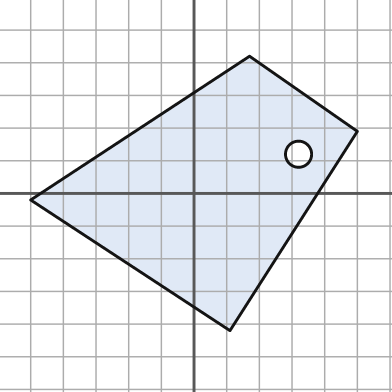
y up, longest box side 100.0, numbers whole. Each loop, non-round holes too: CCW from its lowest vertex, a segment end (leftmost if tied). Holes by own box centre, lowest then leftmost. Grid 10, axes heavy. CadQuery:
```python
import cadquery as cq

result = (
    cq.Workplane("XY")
    .moveTo(11.0, -42.0)
    .lineTo(50.0, 19.0)
    .lineTo(17.0, 42.0)
    .lineTo(-50.0, -2.0)
    .close()
    .moveTo(32.0, 12.0)
    .circle(4.0)
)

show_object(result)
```